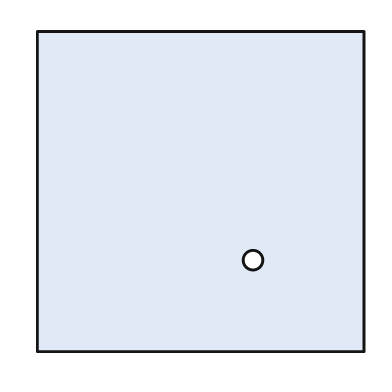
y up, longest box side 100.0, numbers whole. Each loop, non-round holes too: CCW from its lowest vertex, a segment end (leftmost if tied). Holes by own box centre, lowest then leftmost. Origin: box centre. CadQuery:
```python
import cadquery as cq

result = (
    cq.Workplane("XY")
    .moveTo(-50.0, -49.0)
    .lineTo(50.0, -49.0)
    .lineTo(50.0, 49.0)
    .lineTo(-50.0, 49.0)
    .close()
    .moveTo(16.0, -21.0)
    .circle(3.0)
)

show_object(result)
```